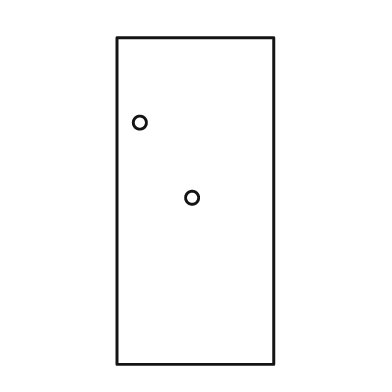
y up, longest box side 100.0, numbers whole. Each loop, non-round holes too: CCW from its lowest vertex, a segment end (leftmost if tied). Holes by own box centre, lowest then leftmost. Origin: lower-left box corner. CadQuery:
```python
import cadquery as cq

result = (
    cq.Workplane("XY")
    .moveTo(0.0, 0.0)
    .lineTo(48.0, 0.0)
    .lineTo(48.0, 100.0)
    .lineTo(0.0, 100.0)
    .close()
    .moveTo(23.0, 51.0)
    .circle(2.0)
    .moveTo(7.0, 74.0)
    .circle(2.0)
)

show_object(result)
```